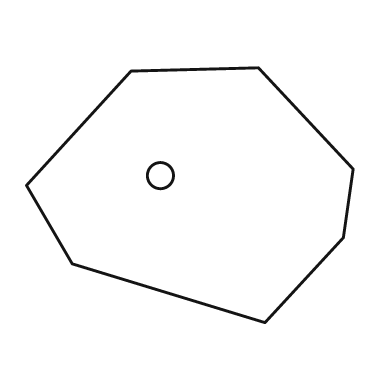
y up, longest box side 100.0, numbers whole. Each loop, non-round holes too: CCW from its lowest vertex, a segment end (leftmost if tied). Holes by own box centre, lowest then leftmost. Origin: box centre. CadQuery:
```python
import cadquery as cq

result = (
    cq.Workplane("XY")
    .moveTo(23.0, -39.0)
    .lineTo(47.0, -13.0)
    .lineTo(50.0, 8.0)
    .lineTo(21.0, 39.0)
    .lineTo(-18.0, 38.0)
    .lineTo(-50.0, 3.0)
    .lineTo(-36.0, -21.0)
    .close()
    .moveTo(-9.0, 6.0)
    .circle(4.0)
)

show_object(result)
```